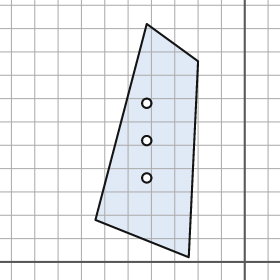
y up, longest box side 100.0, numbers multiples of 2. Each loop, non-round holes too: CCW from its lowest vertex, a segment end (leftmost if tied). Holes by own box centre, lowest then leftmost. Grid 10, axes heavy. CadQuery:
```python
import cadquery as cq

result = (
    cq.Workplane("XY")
    .moveTo(-24.0, 2.0)
    .lineTo(-20.0, 86.0)
    .lineTo(-42.0, 102.0)
    .lineTo(-64.0, 18.0)
    .close()
    .moveTo(-42.0, 36.0)
    .circle(2.0)
    .moveTo(-42.0, 52.0)
    .circle(2.0)
    .moveTo(-42.0, 68.0)
    .circle(2.0)
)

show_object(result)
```